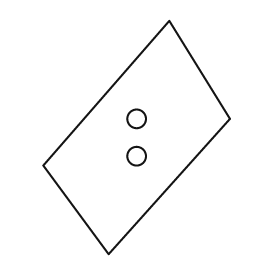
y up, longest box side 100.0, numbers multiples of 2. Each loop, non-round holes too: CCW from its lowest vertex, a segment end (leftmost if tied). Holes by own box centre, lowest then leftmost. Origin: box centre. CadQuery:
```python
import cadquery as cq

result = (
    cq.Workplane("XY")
    .moveTo(-12.0, -50.0)
    .lineTo(40.0, 8.0)
    .lineTo(14.0, 50.0)
    .lineTo(-40.0, -12.0)
    .close()
    .moveTo(0.0, -8.0)
    .circle(4.0)
    .moveTo(0.0, 8.0)
    .circle(4.0)
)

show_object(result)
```